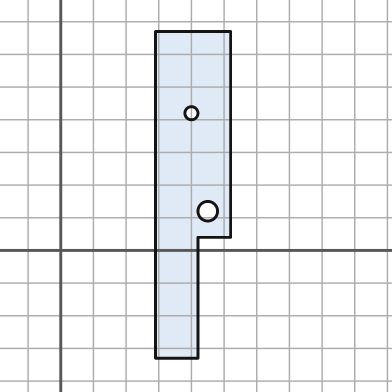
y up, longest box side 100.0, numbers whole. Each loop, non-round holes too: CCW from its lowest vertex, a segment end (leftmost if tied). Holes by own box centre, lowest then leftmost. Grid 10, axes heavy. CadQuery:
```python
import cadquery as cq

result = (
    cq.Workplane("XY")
    .moveTo(29.0, -33.0)
    .lineTo(42.0, -33.0)
    .lineTo(42.0, 4.0)
    .lineTo(52.0, 4.0)
    .lineTo(52.0, 67.0)
    .lineTo(29.0, 67.0)
    .close()
    .moveTo(45.0, 12.0)
    .circle(3.0)
    .moveTo(40.0, 42.0)
    .circle(2.0)
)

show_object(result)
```